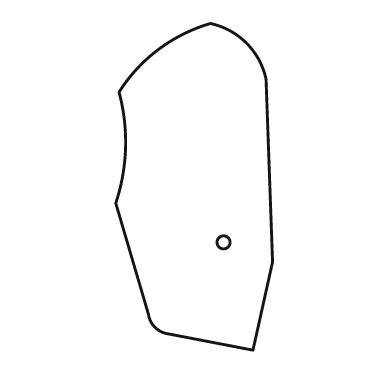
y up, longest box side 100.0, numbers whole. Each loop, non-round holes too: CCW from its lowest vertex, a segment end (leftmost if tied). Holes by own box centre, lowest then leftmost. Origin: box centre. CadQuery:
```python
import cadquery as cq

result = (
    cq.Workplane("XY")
    .moveTo(18.0, -50.0)
    .lineTo(24.0, -23.0)
    .lineTo(22.0, 33.0)
    .threePointArc((16.0, 44.0), (5.0, 50.0))
    .threePointArc((-11.0, 42.0), (-23.0, 29.0))
    .threePointArc((-21.0, 12.0), (-24.0, -5.0))
    .lineTo(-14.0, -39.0)
    .threePointArc((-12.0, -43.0), (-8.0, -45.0))
    .close()
    .moveTo(9.0, -17.0)
    .circle(2.0)
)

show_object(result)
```